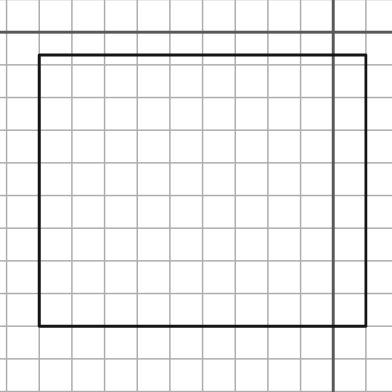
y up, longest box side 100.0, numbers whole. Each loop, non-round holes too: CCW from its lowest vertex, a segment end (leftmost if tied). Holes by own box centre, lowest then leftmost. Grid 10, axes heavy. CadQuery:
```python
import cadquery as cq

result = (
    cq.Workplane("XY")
    .moveTo(-90.0, -90.0)
    .lineTo(10.0, -90.0)
    .lineTo(10.0, -7.0)
    .lineTo(-90.0, -7.0)
    .close()
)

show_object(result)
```